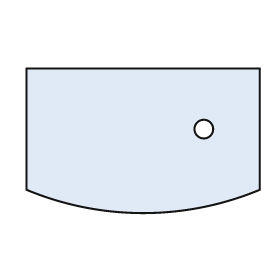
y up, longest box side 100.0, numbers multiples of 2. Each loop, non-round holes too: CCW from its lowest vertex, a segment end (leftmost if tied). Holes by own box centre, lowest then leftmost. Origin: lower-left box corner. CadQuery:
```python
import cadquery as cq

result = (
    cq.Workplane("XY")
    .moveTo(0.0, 10.0)
    .threePointArc((50.0, 0.0), (100.0, 10.0))
    .lineTo(100.0, 62.0)
    .lineTo(0.0, 62.0)
    .close()
    .moveTo(76.0, 36.0)
    .circle(4.0)
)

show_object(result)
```